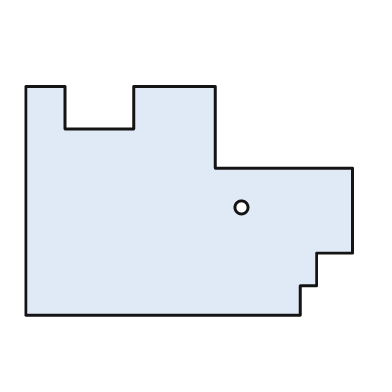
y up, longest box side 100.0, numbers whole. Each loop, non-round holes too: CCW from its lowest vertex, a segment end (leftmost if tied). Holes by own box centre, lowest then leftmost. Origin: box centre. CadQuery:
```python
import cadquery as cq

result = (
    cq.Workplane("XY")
    .moveTo(-50.0, -35.0)
    .lineTo(34.0, -35.0)
    .lineTo(34.0, -26.0)
    .lineTo(39.0, -26.0)
    .lineTo(39.0, -16.0)
    .lineTo(50.0, -16.0)
    .lineTo(50.0, 10.0)
    .lineTo(8.0, 10.0)
    .lineTo(8.0, 35.0)
    .lineTo(-17.0, 35.0)
    .lineTo(-17.0, 22.0)
    .lineTo(-38.0, 22.0)
    .lineTo(-38.0, 35.0)
    .lineTo(-50.0, 35.0)
    .close()
    .moveTo(16.0, -2.0)
    .circle(2.0)
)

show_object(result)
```